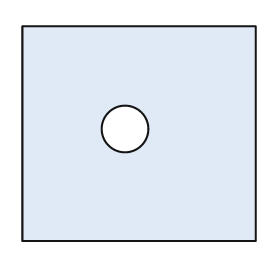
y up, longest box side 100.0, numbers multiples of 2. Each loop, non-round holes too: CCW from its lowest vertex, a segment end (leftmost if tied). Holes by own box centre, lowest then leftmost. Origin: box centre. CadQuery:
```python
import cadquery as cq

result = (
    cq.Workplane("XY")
    .moveTo(-50.0, -46.0)
    .lineTo(50.0, -46.0)
    .lineTo(50.0, 46.0)
    .lineTo(-50.0, 46.0)
    .close()
    .moveTo(-6.0, 2.0)
    .circle(10.0)
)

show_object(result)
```